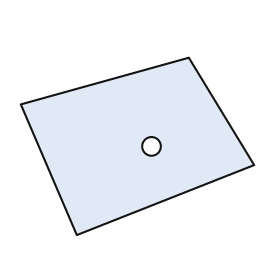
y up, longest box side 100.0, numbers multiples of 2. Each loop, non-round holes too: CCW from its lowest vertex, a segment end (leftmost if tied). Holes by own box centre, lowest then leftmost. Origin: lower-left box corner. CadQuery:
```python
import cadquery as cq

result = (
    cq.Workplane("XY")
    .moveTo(24.0, 0.0)
    .lineTo(100.0, 30.0)
    .lineTo(72.0, 76.0)
    .lineTo(0.0, 56.0)
    .close()
    .moveTo(56.0, 38.0)
    .circle(4.0)
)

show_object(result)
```